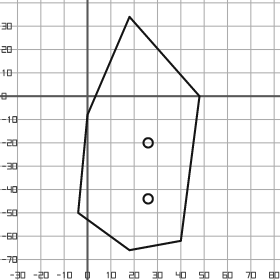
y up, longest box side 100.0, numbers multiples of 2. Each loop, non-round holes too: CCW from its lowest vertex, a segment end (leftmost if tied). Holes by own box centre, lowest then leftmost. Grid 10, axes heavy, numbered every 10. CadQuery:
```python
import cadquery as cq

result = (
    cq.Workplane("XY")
    .moveTo(18.0, -66.0)
    .lineTo(40.0, -62.0)
    .lineTo(48.0, 0.0)
    .lineTo(18.0, 34.0)
    .lineTo(0.0, -8.0)
    .lineTo(-4.0, -50.0)
    .close()
    .moveTo(26.0, -44.0)
    .circle(2.0)
    .moveTo(26.0, -20.0)
    .circle(2.0)
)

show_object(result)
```